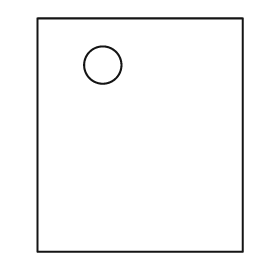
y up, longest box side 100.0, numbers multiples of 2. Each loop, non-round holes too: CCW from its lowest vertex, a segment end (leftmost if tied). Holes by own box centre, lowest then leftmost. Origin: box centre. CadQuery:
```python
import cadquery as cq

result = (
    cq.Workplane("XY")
    .moveTo(-44.0, -50.0)
    .lineTo(44.0, -50.0)
    .lineTo(44.0, 50.0)
    .lineTo(-44.0, 50.0)
    .close()
    .moveTo(-16.0, 30.0)
    .circle(8.0)
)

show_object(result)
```